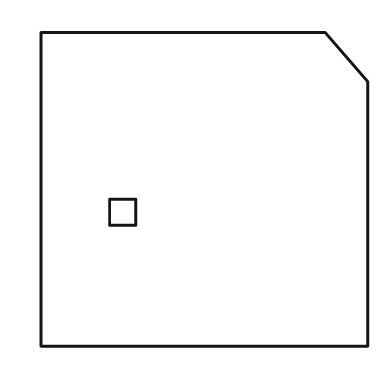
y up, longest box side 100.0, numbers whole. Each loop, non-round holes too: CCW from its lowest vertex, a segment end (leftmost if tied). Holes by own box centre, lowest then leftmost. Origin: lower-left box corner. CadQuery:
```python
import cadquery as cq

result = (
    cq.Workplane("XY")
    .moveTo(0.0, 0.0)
    .lineTo(100.0, 0.0)
    .lineTo(100.0, 81.0)
    .lineTo(87.0, 96.0)
    .lineTo(0.0, 96.0)
    .close()
    .moveTo(21.0, 37.0)
    .lineTo(29.0, 37.0)
    .lineTo(29.0, 45.0)
    .lineTo(21.0, 45.0)
    .close()
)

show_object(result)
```